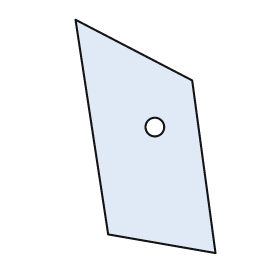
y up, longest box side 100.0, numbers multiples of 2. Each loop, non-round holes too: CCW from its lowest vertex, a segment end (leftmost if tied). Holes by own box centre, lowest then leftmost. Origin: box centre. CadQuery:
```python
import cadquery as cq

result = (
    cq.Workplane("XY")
    .moveTo(30.0, -50.0)
    .lineTo(20.0, 24.0)
    .lineTo(-30.0, 50.0)
    .lineTo(-16.0, -42.0)
    .close()
    .moveTo(4.0, 4.0)
    .circle(4.0)
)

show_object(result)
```